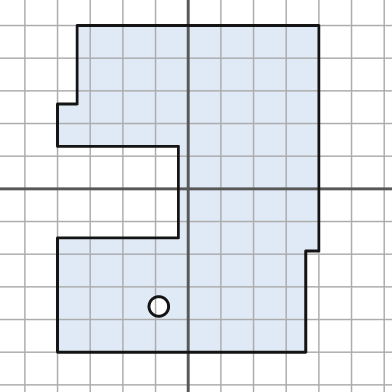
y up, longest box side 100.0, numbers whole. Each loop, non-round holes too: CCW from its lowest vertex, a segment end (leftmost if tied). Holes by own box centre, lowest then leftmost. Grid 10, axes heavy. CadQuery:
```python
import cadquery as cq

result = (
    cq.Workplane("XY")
    .moveTo(-40.0, -50.0)
    .lineTo(36.0, -50.0)
    .lineTo(36.0, -19.0)
    .lineTo(40.0, -19.0)
    .lineTo(40.0, 50.0)
    .lineTo(-34.0, 50.0)
    .lineTo(-34.0, 26.0)
    .lineTo(-40.0, 26.0)
    .lineTo(-40.0, 13.0)
    .lineTo(-3.0, 13.0)
    .lineTo(-3.0, -15.0)
    .lineTo(-40.0, -15.0)
    .close()
    .moveTo(-9.0, -36.0)
    .circle(3.0)
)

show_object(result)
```